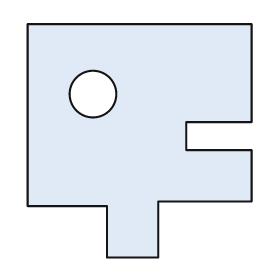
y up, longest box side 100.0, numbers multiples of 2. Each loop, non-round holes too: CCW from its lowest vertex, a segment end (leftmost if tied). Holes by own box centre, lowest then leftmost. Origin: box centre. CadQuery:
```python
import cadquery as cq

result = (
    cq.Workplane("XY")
    .moveTo(-14.0, -50.0)
    .lineTo(8.0, -50.0)
    .lineTo(8.0, -26.0)
    .lineTo(48.0, -26.0)
    .lineTo(48.0, -4.0)
    .lineTo(20.0, -4.0)
    .lineTo(20.0, 8.0)
    .lineTo(48.0, 8.0)
    .lineTo(48.0, 50.0)
    .lineTo(-48.0, 50.0)
    .lineTo(-48.0, -28.0)
    .lineTo(-14.0, -28.0)
    .close()
    .moveTo(-20.0, 20.0)
    .circle(10.0)
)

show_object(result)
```